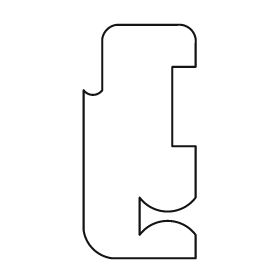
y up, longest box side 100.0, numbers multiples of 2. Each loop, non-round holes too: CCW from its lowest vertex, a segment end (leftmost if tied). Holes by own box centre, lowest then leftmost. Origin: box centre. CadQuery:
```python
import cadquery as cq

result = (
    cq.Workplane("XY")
    .moveTo(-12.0, -50.0)
    .lineTo(24.0, -50.0)
    .lineTo(24.0, -40.0)
    .threePointArc((12.0, -34.0), (0.0, -40.0))
    .lineTo(0.0, -24.0)
    .threePointArc((12.0, -30.0), (24.0, -24.0))
    .lineTo(24.0, -2.0)
    .lineTo(14.0, -2.0)
    .lineTo(14.0, 32.0)
    .lineTo(24.0, 32.0)
    .lineTo(24.0, 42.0)
    .threePointArc((22.0, 48.0), (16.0, 50.0))
    .lineTo(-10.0, 50.0)
    .threePointArc((-14.0, 48.0), (-16.0, 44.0))
    .lineTo(-16.0, 22.0)
    .threePointArc((-20.0, 20.0), (-24.0, 22.0))
    .lineTo(-24.0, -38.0)
    .threePointArc((-20.0, -46.0), (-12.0, -50.0))
    .close()
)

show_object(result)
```